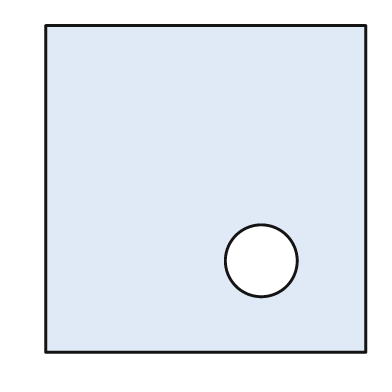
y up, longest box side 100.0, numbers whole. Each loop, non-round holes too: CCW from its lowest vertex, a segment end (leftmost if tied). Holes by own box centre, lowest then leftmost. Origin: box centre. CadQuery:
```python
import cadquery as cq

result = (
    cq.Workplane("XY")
    .moveTo(-49.0, -50.0)
    .lineTo(49.0, -50.0)
    .lineTo(49.0, 50.0)
    .lineTo(-49.0, 50.0)
    .close()
    .moveTo(17.0, -22.0)
    .circle(11.0)
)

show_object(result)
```